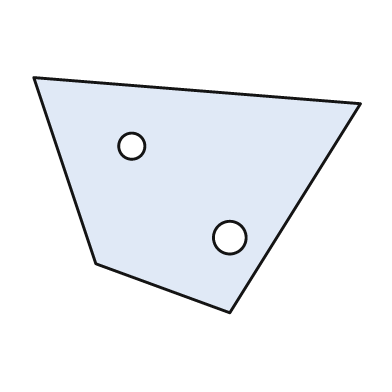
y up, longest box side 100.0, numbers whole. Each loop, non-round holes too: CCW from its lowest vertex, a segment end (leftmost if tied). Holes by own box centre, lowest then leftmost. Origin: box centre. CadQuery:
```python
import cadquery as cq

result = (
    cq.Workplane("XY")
    .moveTo(10.0, -36.0)
    .lineTo(50.0, 28.0)
    .lineTo(-50.0, 36.0)
    .lineTo(-31.0, -21.0)
    .close()
    .moveTo(10.0, -13.0)
    .circle(5.0)
    .moveTo(-20.0, 15.0)
    .circle(4.0)
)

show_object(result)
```